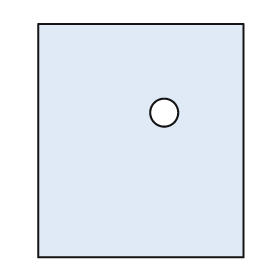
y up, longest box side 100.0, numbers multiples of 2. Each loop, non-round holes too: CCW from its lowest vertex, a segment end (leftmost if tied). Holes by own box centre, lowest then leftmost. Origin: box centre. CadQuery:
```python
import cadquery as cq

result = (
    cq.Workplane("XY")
    .moveTo(-44.0, -50.0)
    .lineTo(44.0, -50.0)
    .lineTo(44.0, 50.0)
    .lineTo(-44.0, 50.0)
    .close()
    .moveTo(10.0, 12.0)
    .circle(6.0)
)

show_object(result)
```